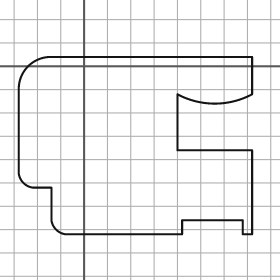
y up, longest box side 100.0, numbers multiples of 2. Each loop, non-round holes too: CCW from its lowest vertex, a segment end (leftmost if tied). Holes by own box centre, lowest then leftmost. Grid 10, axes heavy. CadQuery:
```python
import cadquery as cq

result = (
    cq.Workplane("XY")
    .moveTo(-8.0, -72.0)
    .lineTo(42.0, -72.0)
    .lineTo(42.0, -66.0)
    .lineTo(68.0, -66.0)
    .lineTo(68.0, -72.0)
    .lineTo(72.0, -72.0)
    .lineTo(72.0, -36.0)
    .lineTo(40.0, -36.0)
    .lineTo(40.0, -12.0)
    .threePointArc((56.0, -16.0), (72.0, -12.0))
    .lineTo(72.0, 4.0)
    .lineTo(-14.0, 4.0)
    .threePointArc((-24.0, 0.0), (-28.0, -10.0))
    .lineTo(-28.0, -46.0)
    .threePointArc((-26.0, -50.0), (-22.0, -52.0))
    .lineTo(-14.0, -52.0)
    .lineTo(-14.0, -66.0)
    .threePointArc((-12.0, -70.0), (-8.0, -72.0))
    .close()
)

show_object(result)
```